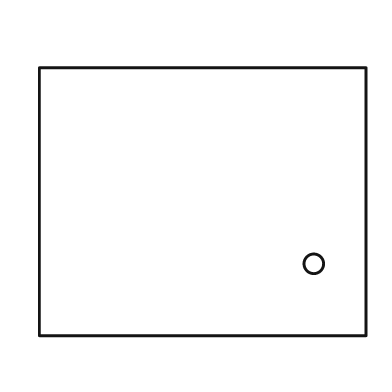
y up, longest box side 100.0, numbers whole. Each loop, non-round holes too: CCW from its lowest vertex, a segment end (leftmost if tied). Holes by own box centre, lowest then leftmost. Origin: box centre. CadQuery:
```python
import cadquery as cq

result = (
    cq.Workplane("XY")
    .moveTo(-50.0, -41.0)
    .lineTo(50.0, -41.0)
    .lineTo(50.0, 41.0)
    .lineTo(-50.0, 41.0)
    .close()
    .moveTo(34.0, -19.0)
    .circle(3.0)
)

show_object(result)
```